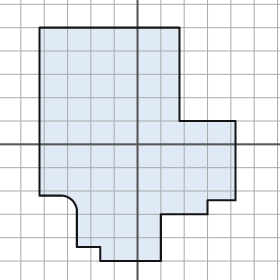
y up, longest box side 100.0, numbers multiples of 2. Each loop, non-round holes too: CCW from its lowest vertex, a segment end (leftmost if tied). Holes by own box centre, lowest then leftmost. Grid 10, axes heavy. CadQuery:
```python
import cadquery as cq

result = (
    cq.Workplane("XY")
    .moveTo(-16.0, -50.0)
    .lineTo(10.0, -50.0)
    .lineTo(10.0, -30.0)
    .lineTo(30.0, -30.0)
    .lineTo(30.0, -24.0)
    .lineTo(42.0, -24.0)
    .lineTo(42.0, 10.0)
    .lineTo(18.0, 10.0)
    .lineTo(18.0, 50.0)
    .lineTo(-42.0, 50.0)
    .lineTo(-42.0, -22.0)
    .lineTo(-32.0, -22.0)
    .threePointArc((-28.0, -24.0), (-26.0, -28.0))
    .lineTo(-26.0, -44.0)
    .lineTo(-16.0, -44.0)
    .close()
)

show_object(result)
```